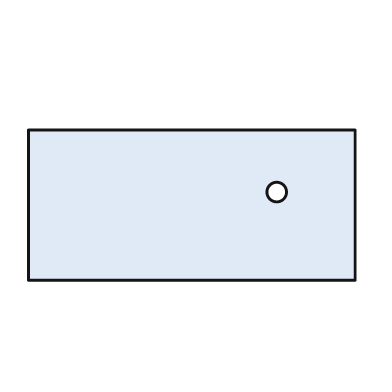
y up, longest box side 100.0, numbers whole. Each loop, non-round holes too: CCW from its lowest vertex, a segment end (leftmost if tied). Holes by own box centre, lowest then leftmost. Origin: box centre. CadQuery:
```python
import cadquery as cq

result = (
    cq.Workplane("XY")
    .moveTo(-50.0, -23.0)
    .lineTo(50.0, -23.0)
    .lineTo(50.0, 23.0)
    .lineTo(-50.0, 23.0)
    .close()
    .moveTo(26.0, 4.0)
    .circle(3.0)
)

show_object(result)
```